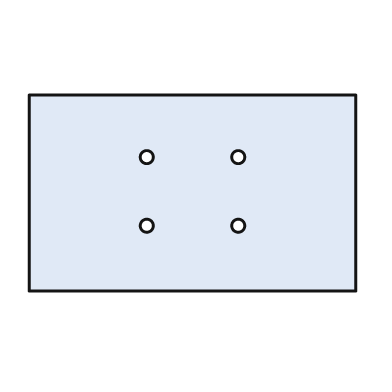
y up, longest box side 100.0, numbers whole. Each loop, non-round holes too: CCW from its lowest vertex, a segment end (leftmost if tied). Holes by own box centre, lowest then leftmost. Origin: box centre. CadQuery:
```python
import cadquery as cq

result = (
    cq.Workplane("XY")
    .moveTo(-50.0, -30.0)
    .lineTo(50.0, -30.0)
    .lineTo(50.0, 30.0)
    .lineTo(-50.0, 30.0)
    .close()
    .moveTo(-14.0, -10.0)
    .circle(2.0)
    .moveTo(14.0, -10.0)
    .circle(2.0)
    .moveTo(-14.0, 11.0)
    .circle(2.0)
    .moveTo(14.0, 11.0)
    .circle(2.0)
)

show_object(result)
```